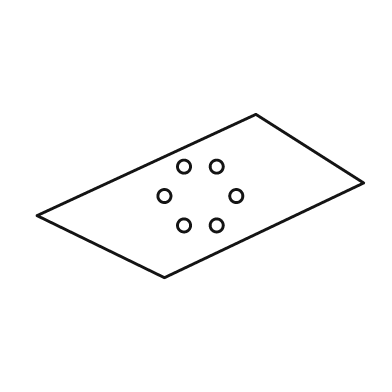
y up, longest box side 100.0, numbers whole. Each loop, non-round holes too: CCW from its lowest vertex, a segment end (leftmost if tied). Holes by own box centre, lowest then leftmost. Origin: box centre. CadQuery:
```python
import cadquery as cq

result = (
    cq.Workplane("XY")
    .moveTo(-11.0, -25.0)
    .lineTo(50.0, 4.0)
    .lineTo(17.0, 25.0)
    .lineTo(-50.0, -6.0)
    .close()
    .moveTo(-5.0, -9.0)
    .circle(2.0)
    .moveTo(5.0, -9.0)
    .circle(2.0)
    .moveTo(-11.0, 0.0)
    .circle(2.0)
    .moveTo(11.0, 0.0)
    .circle(2.0)
    .moveTo(-5.0, 9.0)
    .circle(2.0)
    .moveTo(5.0, 9.0)
    .circle(2.0)
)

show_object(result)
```